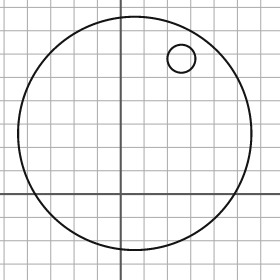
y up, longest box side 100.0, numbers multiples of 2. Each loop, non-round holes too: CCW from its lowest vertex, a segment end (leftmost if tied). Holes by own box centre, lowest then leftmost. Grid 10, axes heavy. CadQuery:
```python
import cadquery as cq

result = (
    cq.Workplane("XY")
    .moveTo(6.0, 26.0)
    .circle(50.0)
    .moveTo(26.0, 58.0)
    .circle(6.0)
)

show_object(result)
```